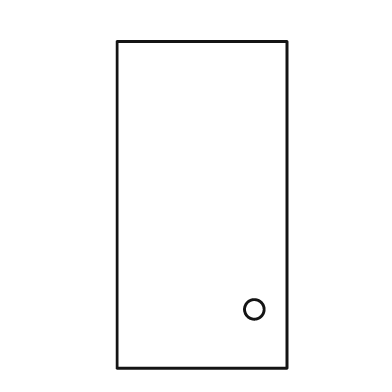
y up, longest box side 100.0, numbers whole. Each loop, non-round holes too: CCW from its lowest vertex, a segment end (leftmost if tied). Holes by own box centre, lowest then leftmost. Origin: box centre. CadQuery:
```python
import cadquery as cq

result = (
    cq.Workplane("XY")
    .moveTo(-26.0, -50.0)
    .lineTo(26.0, -50.0)
    .lineTo(26.0, 50.0)
    .lineTo(-26.0, 50.0)
    .close()
    .moveTo(16.0, -32.0)
    .circle(3.0)
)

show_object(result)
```